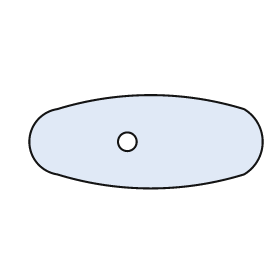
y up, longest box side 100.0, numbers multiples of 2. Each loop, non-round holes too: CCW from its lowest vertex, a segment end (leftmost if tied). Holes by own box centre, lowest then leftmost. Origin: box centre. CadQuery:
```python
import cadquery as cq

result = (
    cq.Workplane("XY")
    .moveTo(-38.0, -14.0)
    .threePointArc((2.0, -20.0), (42.0, -14.0))
    .threePointArc((50.0, 0.0), (42.0, 14.0))
    .threePointArc((2.0, 20.0), (-38.0, 14.0))
    .threePointArc((-50.0, 0.0), (-38.0, -14.0))
    .close()
    .moveTo(-8.0, 0.0)
    .circle(4.0)
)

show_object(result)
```